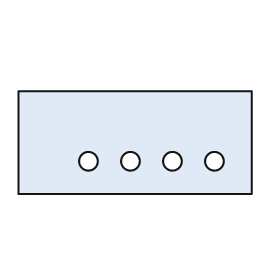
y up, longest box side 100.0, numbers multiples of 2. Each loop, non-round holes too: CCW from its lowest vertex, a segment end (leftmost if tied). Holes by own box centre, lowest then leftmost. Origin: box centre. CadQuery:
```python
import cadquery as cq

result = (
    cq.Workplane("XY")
    .moveTo(-50.0, -22.0)
    .lineTo(50.0, -22.0)
    .lineTo(50.0, 22.0)
    .lineTo(-50.0, 22.0)
    .close()
    .moveTo(-20.0, -8.0)
    .circle(4.0)
    .moveTo(-2.0, -8.0)
    .circle(4.0)
    .moveTo(16.0, -8.0)
    .circle(4.0)
    .moveTo(34.0, -8.0)
    .circle(4.0)
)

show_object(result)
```